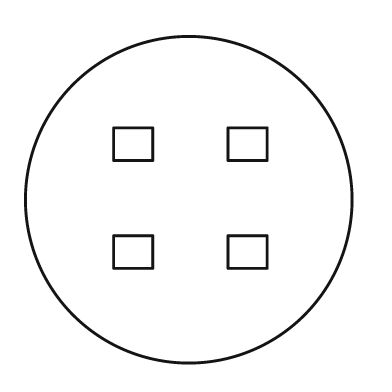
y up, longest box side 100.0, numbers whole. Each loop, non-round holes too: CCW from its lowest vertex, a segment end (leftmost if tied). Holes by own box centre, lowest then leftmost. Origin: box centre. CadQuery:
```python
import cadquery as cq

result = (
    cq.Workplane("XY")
    .moveTo(0.0, 0.0)
    .circle(50.0)
    .moveTo(-23.0, -21.0)
    .lineTo(-11.0, -21.0)
    .lineTo(-11.0, -11.0)
    .lineTo(-23.0, -11.0)
    .close()
    .moveTo(12.0, -21.0)
    .lineTo(24.0, -21.0)
    .lineTo(24.0, -11.0)
    .lineTo(12.0, -11.0)
    .close()
    .moveTo(-23.0, 12.0)
    .lineTo(-11.0, 12.0)
    .lineTo(-11.0, 22.0)
    .lineTo(-23.0, 22.0)
    .close()
    .moveTo(12.0, 12.0)
    .lineTo(24.0, 12.0)
    .lineTo(24.0, 22.0)
    .lineTo(12.0, 22.0)
    .close()
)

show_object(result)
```